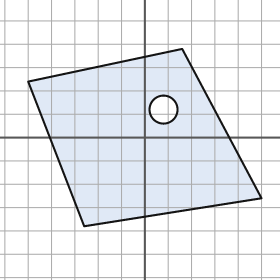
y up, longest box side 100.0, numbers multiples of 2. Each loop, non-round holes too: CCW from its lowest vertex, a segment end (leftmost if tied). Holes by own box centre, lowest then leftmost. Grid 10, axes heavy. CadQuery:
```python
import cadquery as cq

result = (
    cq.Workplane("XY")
    .moveTo(-26.0, -38.0)
    .lineTo(50.0, -26.0)
    .lineTo(16.0, 38.0)
    .lineTo(-50.0, 24.0)
    .close()
    .moveTo(8.0, 12.0)
    .circle(6.0)
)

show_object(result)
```